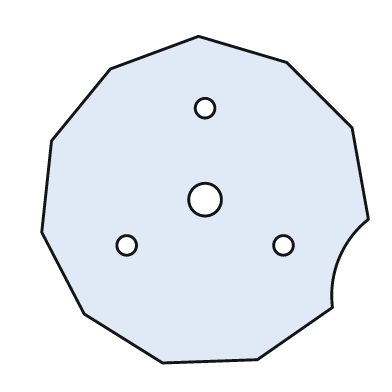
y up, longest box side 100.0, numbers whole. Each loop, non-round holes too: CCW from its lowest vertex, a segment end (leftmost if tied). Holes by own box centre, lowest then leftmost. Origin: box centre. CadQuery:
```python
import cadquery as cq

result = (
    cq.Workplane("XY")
    .moveTo(-13.0, -50.0)
    .lineTo(16.0, -49.0)
    .lineTo(39.0, -33.0)
    .threePointArc((41.0, -18.0), (50.0, -6.0))
    .lineTo(45.0, 22.0)
    .lineTo(25.0, 42.0)
    .lineTo(-2.0, 50.0)
    .lineTo(-29.0, 40.0)
    .lineTo(-47.0, 18.0)
    .lineTo(-50.0, -10.0)
    .lineTo(-37.0, -35.0)
    .close()
    .moveTo(-24.0, -14.0)
    .circle(3.0)
    .moveTo(24.0, -14.0)
    .circle(3.0)
    .moveTo(0.0, 0.0)
    .circle(5.0)
    .moveTo(0.0, 28.0)
    .circle(3.0)
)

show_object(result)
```